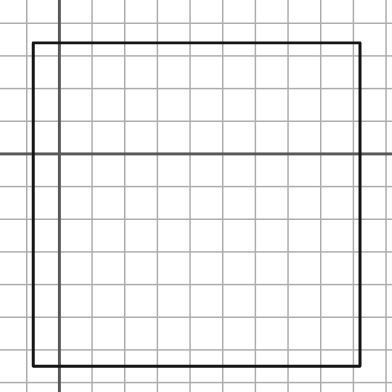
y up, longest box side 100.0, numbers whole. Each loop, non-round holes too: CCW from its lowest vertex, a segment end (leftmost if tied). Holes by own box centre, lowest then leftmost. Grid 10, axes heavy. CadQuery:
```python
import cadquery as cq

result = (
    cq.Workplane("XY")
    .moveTo(-8.0, -65.0)
    .lineTo(92.0, -65.0)
    .lineTo(92.0, 34.0)
    .lineTo(-8.0, 34.0)
    .close()
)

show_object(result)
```